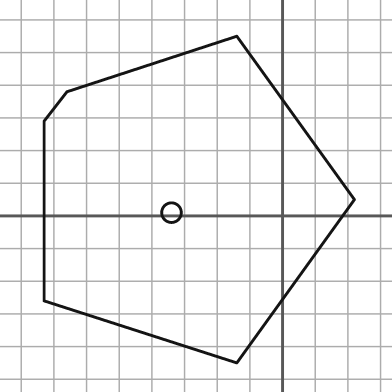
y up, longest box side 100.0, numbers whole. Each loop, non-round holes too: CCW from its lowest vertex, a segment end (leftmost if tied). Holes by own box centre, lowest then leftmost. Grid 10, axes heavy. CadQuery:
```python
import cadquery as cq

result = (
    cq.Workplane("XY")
    .moveTo(-14.0, -45.0)
    .lineTo(22.0, 5.0)
    .lineTo(-14.0, 55.0)
    .lineTo(-66.0, 38.0)
    .lineTo(-73.0, 29.0)
    .lineTo(-73.0, -26.0)
    .close()
    .moveTo(-34.0, 1.0)
    .circle(3.0)
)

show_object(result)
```